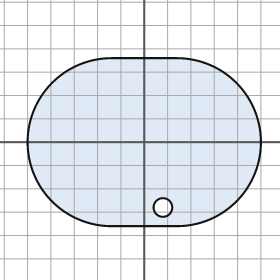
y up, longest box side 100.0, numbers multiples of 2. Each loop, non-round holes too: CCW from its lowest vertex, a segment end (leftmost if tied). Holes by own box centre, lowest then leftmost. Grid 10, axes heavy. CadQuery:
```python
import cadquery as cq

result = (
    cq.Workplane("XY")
    .moveTo(-14.0, -36.0)
    .lineTo(14.0, -36.0)
    .threePointArc((50.0, 0.0), (14.0, 36.0))
    .lineTo(-14.0, 36.0)
    .threePointArc((-50.0, 0.0), (-14.0, -36.0))
    .close()
    .moveTo(8.0, -28.0)
    .circle(4.0)
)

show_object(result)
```